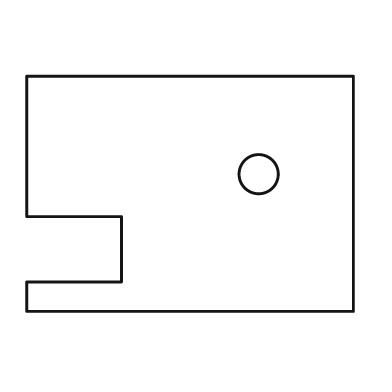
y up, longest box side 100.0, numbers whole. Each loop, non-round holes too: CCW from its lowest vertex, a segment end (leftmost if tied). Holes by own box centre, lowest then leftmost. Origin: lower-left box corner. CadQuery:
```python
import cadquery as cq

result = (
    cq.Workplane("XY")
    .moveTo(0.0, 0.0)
    .lineTo(100.0, 0.0)
    .lineTo(100.0, 72.0)
    .lineTo(0.0, 72.0)
    .lineTo(0.0, 29.0)
    .lineTo(29.0, 29.0)
    .lineTo(29.0, 9.0)
    .lineTo(0.0, 9.0)
    .close()
    .moveTo(71.0, 42.0)
    .circle(6.0)
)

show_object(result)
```